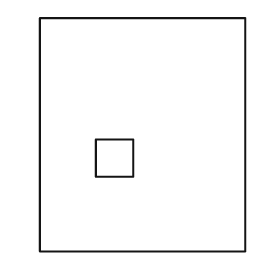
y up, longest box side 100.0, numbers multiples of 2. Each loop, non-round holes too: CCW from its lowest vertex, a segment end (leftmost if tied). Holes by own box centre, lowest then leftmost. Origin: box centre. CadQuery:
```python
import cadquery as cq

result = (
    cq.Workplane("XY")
    .moveTo(-44.0, -50.0)
    .lineTo(44.0, -50.0)
    .lineTo(44.0, 50.0)
    .lineTo(-44.0, 50.0)
    .close()
    .moveTo(-20.0, -18.0)
    .lineTo(-4.0, -18.0)
    .lineTo(-4.0, -2.0)
    .lineTo(-20.0, -2.0)
    .close()
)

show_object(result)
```